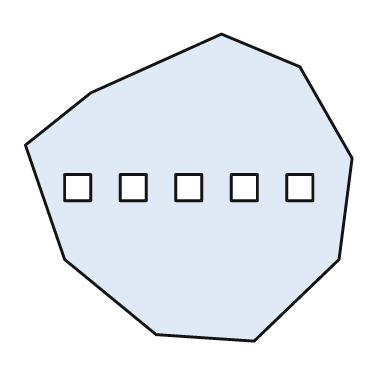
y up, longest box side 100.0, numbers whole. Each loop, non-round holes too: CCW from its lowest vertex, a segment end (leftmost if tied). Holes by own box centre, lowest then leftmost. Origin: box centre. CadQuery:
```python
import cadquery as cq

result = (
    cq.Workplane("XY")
    .moveTo(20.0, -47.0)
    .lineTo(46.0, -22.0)
    .lineTo(50.0, 9.0)
    .lineTo(34.0, 37.0)
    .lineTo(10.0, 47.0)
    .lineTo(-30.0, 29.0)
    .lineTo(-50.0, 13.0)
    .lineTo(-38.0, -22.0)
    .lineTo(-10.0, -45.0)
    .close()
    .moveTo(-38.0, -4.0)
    .lineTo(-30.0, -4.0)
    .lineTo(-30.0, 4.0)
    .lineTo(-38.0, 4.0)
    .close()
    .moveTo(-21.0, -4.0)
    .lineTo(-13.0, -4.0)
    .lineTo(-13.0, 4.0)
    .lineTo(-21.0, 4.0)
    .close()
    .moveTo(-4.0, -4.0)
    .lineTo(4.0, -4.0)
    .lineTo(4.0, 4.0)
    .lineTo(-4.0, 4.0)
    .close()
    .moveTo(13.0, -4.0)
    .lineTo(21.0, -4.0)
    .lineTo(21.0, 4.0)
    .lineTo(13.0, 4.0)
    .close()
    .moveTo(30.0, -4.0)
    .lineTo(38.0, -4.0)
    .lineTo(38.0, 4.0)
    .lineTo(30.0, 4.0)
    .close()
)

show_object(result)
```